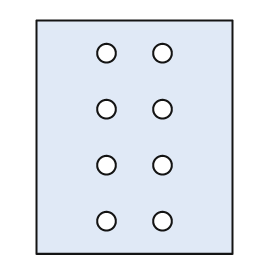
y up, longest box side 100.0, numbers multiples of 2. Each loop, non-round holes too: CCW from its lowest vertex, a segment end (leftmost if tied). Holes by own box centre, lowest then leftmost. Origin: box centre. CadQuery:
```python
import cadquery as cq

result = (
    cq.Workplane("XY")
    .moveTo(-42.0, -50.0)
    .lineTo(42.0, -50.0)
    .lineTo(42.0, 50.0)
    .lineTo(-42.0, 50.0)
    .close()
    .moveTo(-12.0, -36.0)
    .circle(4.0)
    .moveTo(12.0, -36.0)
    .circle(4.0)
    .moveTo(-12.0, -12.0)
    .circle(4.0)
    .moveTo(12.0, -12.0)
    .circle(4.0)
    .moveTo(-12.0, 12.0)
    .circle(4.0)
    .moveTo(12.0, 12.0)
    .circle(4.0)
    .moveTo(-12.0, 36.0)
    .circle(4.0)
    .moveTo(12.0, 36.0)
    .circle(4.0)
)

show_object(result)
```